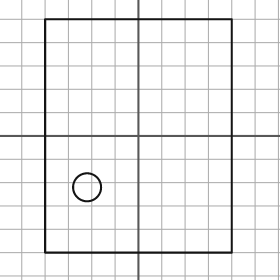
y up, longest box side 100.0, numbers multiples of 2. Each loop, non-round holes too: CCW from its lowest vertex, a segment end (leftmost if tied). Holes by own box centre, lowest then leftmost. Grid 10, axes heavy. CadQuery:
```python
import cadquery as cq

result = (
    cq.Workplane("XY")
    .moveTo(-40.0, -50.0)
    .lineTo(40.0, -50.0)
    .lineTo(40.0, 50.0)
    .lineTo(-40.0, 50.0)
    .close()
    .moveTo(-22.0, -22.0)
    .circle(6.0)
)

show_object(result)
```